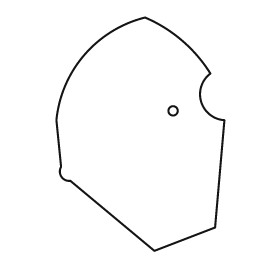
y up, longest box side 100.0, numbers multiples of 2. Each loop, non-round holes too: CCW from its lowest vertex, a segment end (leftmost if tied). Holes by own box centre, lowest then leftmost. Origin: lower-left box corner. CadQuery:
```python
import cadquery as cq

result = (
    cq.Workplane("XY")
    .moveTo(42.0, 0.0)
    .lineTo(68.0, 10.0)
    .lineTo(72.0, 56.0)
    .threePointArc((62.0, 64.0), (66.0, 76.0))
    .threePointArc((54.0, 90.0), (38.0, 100.0))
    .threePointArc((12.0, 84.0), (0.0, 56.0))
    .lineTo(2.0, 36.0)
    .threePointArc((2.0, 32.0), (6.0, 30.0))
    .close()
    .moveTo(50.0, 60.0)
    .circle(2.0)
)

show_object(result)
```